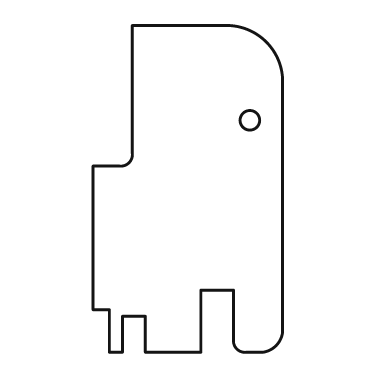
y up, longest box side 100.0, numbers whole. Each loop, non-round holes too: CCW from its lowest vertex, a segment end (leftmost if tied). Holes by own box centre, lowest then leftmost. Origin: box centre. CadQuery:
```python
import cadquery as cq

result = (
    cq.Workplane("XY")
    .moveTo(-24.0, -50.0)
    .lineTo(-20.0, -50.0)
    .lineTo(-20.0, -39.0)
    .lineTo(-13.0, -39.0)
    .lineTo(-13.0, -50.0)
    .lineTo(4.0, -50.0)
    .lineTo(4.0, -31.0)
    .lineTo(14.0, -31.0)
    .lineTo(14.0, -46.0)
    .threePointArc((15.0, -49.0), (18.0, -50.0))
    .lineTo(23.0, -50.0)
    .threePointArc((27.0, -48.0), (29.0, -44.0))
    .lineTo(29.0, 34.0)
    .threePointArc((24.0, 45.0), (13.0, 50.0))
    .lineTo(-17.0, 50.0)
    .lineTo(-17.0, 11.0)
    .threePointArc((-18.0, 8.0), (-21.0, 7.0))
    .lineTo(-29.0, 7.0)
    .lineTo(-29.0, -37.0)
    .lineTo(-24.0, -37.0)
    .close()
    .moveTo(19.0, 21.0)
    .circle(3.0)
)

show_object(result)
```